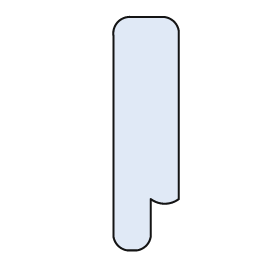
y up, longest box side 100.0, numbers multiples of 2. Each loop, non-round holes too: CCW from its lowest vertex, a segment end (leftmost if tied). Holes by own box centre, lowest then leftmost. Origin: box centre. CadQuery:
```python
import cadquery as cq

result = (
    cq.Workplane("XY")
    .moveTo(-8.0, -50.0)
    .lineTo(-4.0, -50.0)
    .threePointArc((0.0, -48.0), (2.0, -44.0))
    .lineTo(2.0, -28.0)
    .threePointArc((8.0, -30.0), (14.0, -28.0))
    .lineTo(14.0, 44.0)
    .threePointArc((12.0, 48.0), (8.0, 50.0))
    .lineTo(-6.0, 50.0)
    .threePointArc((-12.0, 48.0), (-14.0, 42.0))
    .lineTo(-14.0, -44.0)
    .threePointArc((-12.0, -48.0), (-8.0, -50.0))
    .close()
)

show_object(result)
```